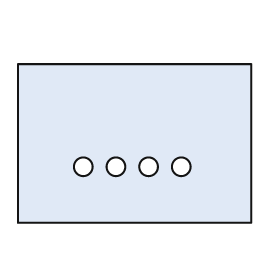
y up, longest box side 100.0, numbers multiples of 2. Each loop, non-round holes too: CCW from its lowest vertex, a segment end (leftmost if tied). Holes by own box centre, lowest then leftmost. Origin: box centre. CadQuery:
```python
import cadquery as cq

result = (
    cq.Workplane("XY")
    .moveTo(-50.0, -34.0)
    .lineTo(50.0, -34.0)
    .lineTo(50.0, 34.0)
    .lineTo(-50.0, 34.0)
    .close()
    .moveTo(-22.0, -10.0)
    .circle(4.0)
    .moveTo(-8.0, -10.0)
    .circle(4.0)
    .moveTo(6.0, -10.0)
    .circle(4.0)
    .moveTo(20.0, -10.0)
    .circle(4.0)
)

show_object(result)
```